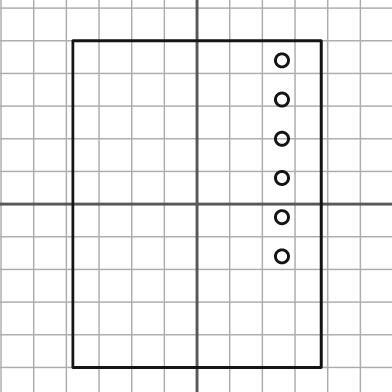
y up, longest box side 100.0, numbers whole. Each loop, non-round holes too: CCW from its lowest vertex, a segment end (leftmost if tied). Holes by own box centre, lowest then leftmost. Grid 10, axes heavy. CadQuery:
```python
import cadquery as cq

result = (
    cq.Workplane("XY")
    .moveTo(-38.0, -50.0)
    .lineTo(38.0, -50.0)
    .lineTo(38.0, 50.0)
    .lineTo(-38.0, 50.0)
    .close()
    .moveTo(26.0, -16.0)
    .circle(2.0)
    .moveTo(26.0, -4.0)
    .circle(2.0)
    .moveTo(26.0, 8.0)
    .circle(2.0)
    .moveTo(26.0, 20.0)
    .circle(2.0)
    .moveTo(26.0, 32.0)
    .circle(2.0)
    .moveTo(26.0, 44.0)
    .circle(2.0)
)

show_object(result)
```